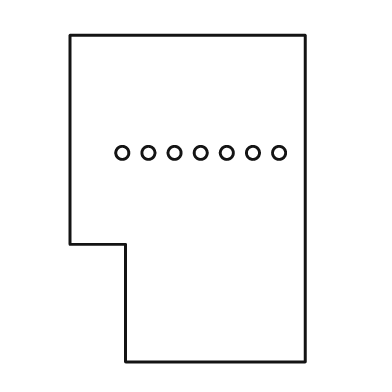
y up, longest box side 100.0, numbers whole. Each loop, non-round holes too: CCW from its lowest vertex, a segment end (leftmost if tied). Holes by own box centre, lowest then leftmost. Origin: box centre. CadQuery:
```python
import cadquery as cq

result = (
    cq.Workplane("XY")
    .moveTo(-19.0, -50.0)
    .lineTo(36.0, -50.0)
    .lineTo(36.0, 50.0)
    .lineTo(-36.0, 50.0)
    .lineTo(-36.0, -14.0)
    .lineTo(-19.0, -14.0)
    .close()
    .moveTo(-20.0, 14.0)
    .circle(2.0)
    .moveTo(-12.0, 14.0)
    .circle(2.0)
    .moveTo(-4.0, 14.0)
    .circle(2.0)
    .moveTo(4.0, 14.0)
    .circle(2.0)
    .moveTo(12.0, 14.0)
    .circle(2.0)
    .moveTo(20.0, 14.0)
    .circle(2.0)
    .moveTo(28.0, 14.0)
    .circle(2.0)
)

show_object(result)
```